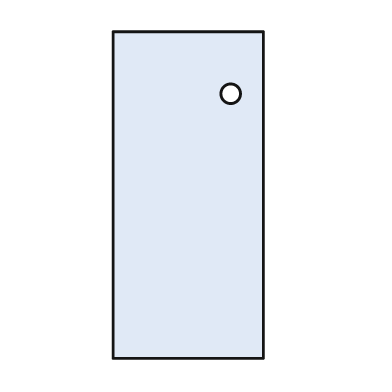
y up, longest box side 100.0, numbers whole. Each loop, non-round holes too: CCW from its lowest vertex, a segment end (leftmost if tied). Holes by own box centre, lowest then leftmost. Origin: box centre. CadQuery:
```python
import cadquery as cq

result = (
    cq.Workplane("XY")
    .moveTo(-23.0, -50.0)
    .lineTo(23.0, -50.0)
    .lineTo(23.0, 50.0)
    .lineTo(-23.0, 50.0)
    .close()
    .moveTo(13.0, 31.0)
    .circle(3.0)
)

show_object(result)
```